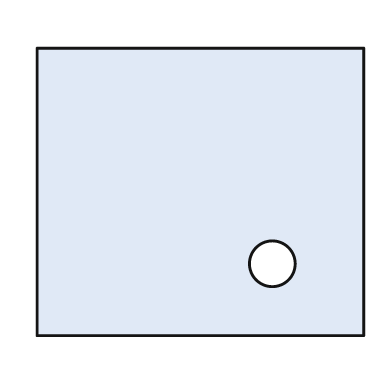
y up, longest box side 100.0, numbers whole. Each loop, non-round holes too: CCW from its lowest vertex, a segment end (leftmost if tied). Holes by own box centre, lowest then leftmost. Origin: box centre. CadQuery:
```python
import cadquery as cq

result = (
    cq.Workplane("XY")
    .moveTo(-50.0, -44.0)
    .lineTo(50.0, -44.0)
    .lineTo(50.0, 44.0)
    .lineTo(-50.0, 44.0)
    .close()
    .moveTo(22.0, -22.0)
    .circle(7.0)
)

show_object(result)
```